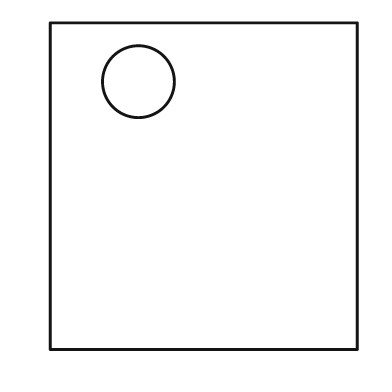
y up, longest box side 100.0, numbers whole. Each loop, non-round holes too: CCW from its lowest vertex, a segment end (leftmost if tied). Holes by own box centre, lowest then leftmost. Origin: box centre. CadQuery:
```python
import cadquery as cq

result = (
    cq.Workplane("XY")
    .moveTo(-47.0, -50.0)
    .lineTo(47.0, -50.0)
    .lineTo(47.0, 50.0)
    .lineTo(-47.0, 50.0)
    .close()
    .moveTo(-20.0, 32.0)
    .circle(11.0)
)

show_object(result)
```